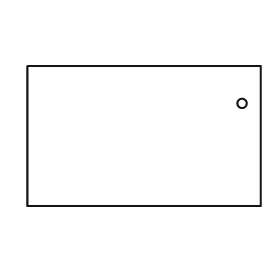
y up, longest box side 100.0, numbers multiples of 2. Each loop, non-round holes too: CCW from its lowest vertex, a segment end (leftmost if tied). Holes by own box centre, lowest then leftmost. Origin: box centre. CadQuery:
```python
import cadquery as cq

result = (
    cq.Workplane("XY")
    .moveTo(-50.0, -30.0)
    .lineTo(50.0, -30.0)
    .lineTo(50.0, 30.0)
    .lineTo(-50.0, 30.0)
    .close()
    .moveTo(42.0, 14.0)
    .circle(2.0)
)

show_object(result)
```